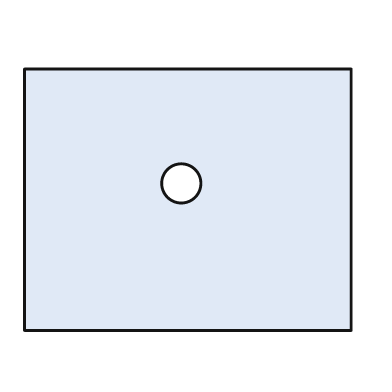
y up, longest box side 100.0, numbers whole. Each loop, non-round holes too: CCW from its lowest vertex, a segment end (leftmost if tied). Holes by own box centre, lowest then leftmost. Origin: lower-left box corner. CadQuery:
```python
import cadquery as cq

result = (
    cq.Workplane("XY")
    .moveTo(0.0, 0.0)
    .lineTo(100.0, 0.0)
    .lineTo(100.0, 80.0)
    .lineTo(0.0, 80.0)
    .close()
    .moveTo(48.0, 45.0)
    .circle(6.0)
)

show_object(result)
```